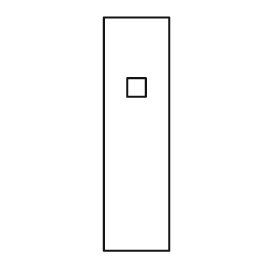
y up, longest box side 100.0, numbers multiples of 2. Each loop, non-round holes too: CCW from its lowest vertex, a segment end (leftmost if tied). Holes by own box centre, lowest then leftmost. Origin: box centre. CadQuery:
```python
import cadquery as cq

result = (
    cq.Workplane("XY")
    .moveTo(-14.0, -50.0)
    .lineTo(14.0, -50.0)
    .lineTo(14.0, 50.0)
    .lineTo(-14.0, 50.0)
    .close()
    .moveTo(-4.0, 16.0)
    .lineTo(4.0, 16.0)
    .lineTo(4.0, 24.0)
    .lineTo(-4.0, 24.0)
    .close()
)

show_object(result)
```